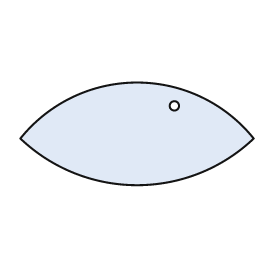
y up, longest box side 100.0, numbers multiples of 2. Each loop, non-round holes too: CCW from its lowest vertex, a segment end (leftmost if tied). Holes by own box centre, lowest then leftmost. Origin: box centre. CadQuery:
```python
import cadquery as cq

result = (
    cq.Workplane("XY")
    .moveTo(-50.0, -2.0)
    .threePointArc((0.0, -22.0), (50.0, -2.0))
    .threePointArc((0.0, 22.0), (-50.0, -2.0))
    .close()
    .moveTo(16.0, 12.0)
    .circle(2.0)
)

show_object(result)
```